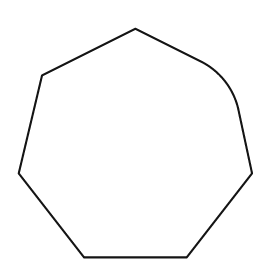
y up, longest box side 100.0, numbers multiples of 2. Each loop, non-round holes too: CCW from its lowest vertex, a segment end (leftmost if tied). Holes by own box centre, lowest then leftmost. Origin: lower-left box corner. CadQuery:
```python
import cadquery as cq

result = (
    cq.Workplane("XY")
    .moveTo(28.0, 0.0)
    .lineTo(72.0, 0.0)
    .lineTo(100.0, 36.0)
    .lineTo(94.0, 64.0)
    .threePointArc((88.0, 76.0), (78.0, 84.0))
    .lineTo(50.0, 98.0)
    .lineTo(10.0, 78.0)
    .lineTo(0.0, 36.0)
    .close()
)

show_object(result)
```